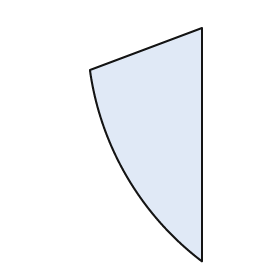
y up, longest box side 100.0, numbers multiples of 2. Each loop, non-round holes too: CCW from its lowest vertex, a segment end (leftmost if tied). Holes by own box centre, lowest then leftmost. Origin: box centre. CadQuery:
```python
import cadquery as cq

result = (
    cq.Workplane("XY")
    .moveTo(24.0, -50.0)
    .lineTo(24.0, 50.0)
    .lineTo(-24.0, 32.0)
    .threePointArc((-8.0, -14.0), (24.0, -50.0))
    .close()
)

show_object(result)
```